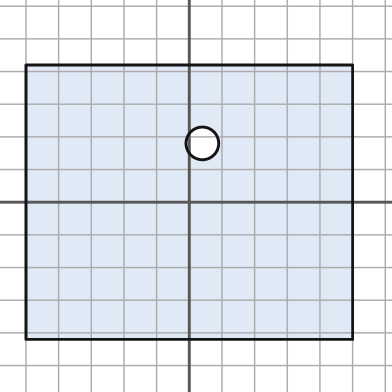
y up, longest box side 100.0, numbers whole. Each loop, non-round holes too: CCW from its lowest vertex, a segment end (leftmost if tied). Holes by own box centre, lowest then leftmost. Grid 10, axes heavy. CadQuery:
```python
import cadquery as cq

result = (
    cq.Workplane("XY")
    .moveTo(-50.0, -42.0)
    .lineTo(50.0, -42.0)
    .lineTo(50.0, 42.0)
    .lineTo(-50.0, 42.0)
    .close()
    .moveTo(4.0, 18.0)
    .circle(5.0)
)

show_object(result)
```